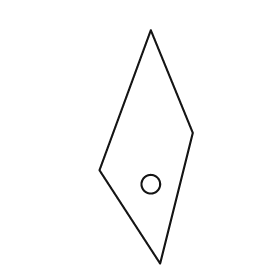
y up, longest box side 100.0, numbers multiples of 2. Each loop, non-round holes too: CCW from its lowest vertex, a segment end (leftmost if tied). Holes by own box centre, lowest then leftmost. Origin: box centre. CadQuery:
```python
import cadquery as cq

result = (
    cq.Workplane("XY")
    .moveTo(6.0, -50.0)
    .lineTo(20.0, 6.0)
    .lineTo(2.0, 50.0)
    .lineTo(-20.0, -10.0)
    .close()
    .moveTo(2.0, -16.0)
    .circle(4.0)
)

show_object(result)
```